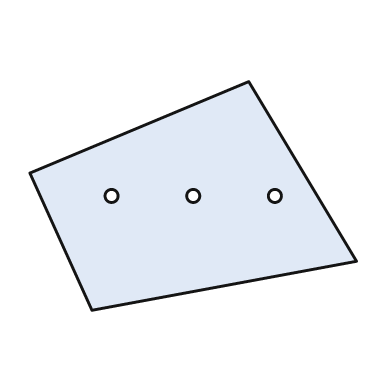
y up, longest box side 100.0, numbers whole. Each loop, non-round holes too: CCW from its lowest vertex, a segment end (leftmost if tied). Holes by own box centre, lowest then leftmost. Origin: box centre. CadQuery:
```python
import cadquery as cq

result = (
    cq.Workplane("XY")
    .moveTo(-31.0, -35.0)
    .lineTo(50.0, -20.0)
    .lineTo(17.0, 35.0)
    .lineTo(-50.0, 7.0)
    .close()
    .moveTo(-25.0, 0.0)
    .circle(2.0)
    .moveTo(0.0, 0.0)
    .circle(2.0)
    .moveTo(25.0, 0.0)
    .circle(2.0)
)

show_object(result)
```